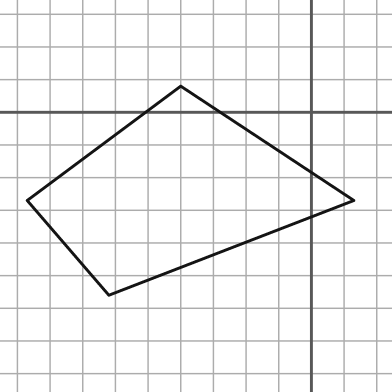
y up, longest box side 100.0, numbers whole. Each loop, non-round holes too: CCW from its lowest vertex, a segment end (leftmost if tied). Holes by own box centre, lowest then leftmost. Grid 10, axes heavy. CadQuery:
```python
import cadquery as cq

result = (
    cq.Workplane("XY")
    .moveTo(-62.0, -56.0)
    .lineTo(13.0, -27.0)
    .lineTo(-40.0, 8.0)
    .lineTo(-87.0, -27.0)
    .close()
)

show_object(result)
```